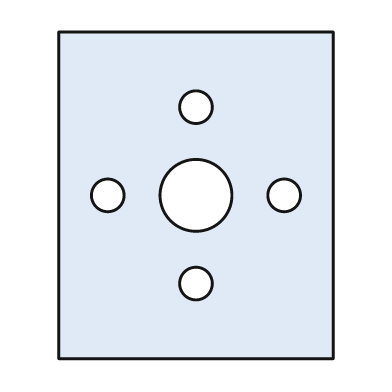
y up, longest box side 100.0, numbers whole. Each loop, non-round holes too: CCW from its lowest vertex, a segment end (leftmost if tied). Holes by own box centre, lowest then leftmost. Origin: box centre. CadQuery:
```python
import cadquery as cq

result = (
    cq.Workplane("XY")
    .moveTo(-42.0, -50.0)
    .lineTo(42.0, -50.0)
    .lineTo(42.0, 50.0)
    .lineTo(-42.0, 50.0)
    .close()
    .moveTo(0.0, -27.0)
    .circle(5.0)
    .moveTo(-27.0, 0.0)
    .circle(5.0)
    .moveTo(0.0, 0.0)
    .circle(11.0)
    .moveTo(27.0, 0.0)
    .circle(5.0)
    .moveTo(0.0, 27.0)
    .circle(5.0)
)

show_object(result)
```